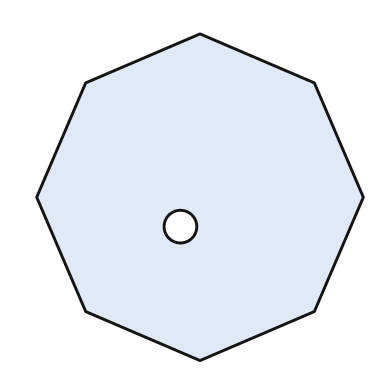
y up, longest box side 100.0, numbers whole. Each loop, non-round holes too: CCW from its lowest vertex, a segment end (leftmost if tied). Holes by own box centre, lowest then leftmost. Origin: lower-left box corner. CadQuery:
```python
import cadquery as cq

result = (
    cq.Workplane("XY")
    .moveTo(50.0, 0.0)
    .lineTo(85.0, 15.0)
    .lineTo(100.0, 50.0)
    .lineTo(85.0, 85.0)
    .lineTo(50.0, 100.0)
    .lineTo(15.0, 85.0)
    .lineTo(0.0, 50.0)
    .lineTo(15.0, 15.0)
    .close()
    .moveTo(44.0, 41.0)
    .circle(5.0)
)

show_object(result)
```